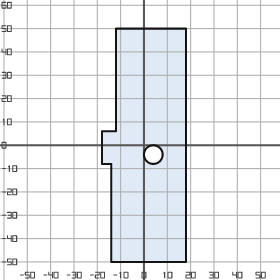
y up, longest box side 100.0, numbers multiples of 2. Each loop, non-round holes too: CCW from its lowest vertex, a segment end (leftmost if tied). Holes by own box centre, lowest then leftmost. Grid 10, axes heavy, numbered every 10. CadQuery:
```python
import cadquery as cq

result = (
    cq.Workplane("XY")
    .moveTo(-14.0, -50.0)
    .lineTo(18.0, -50.0)
    .lineTo(18.0, 50.0)
    .lineTo(-12.0, 50.0)
    .lineTo(-12.0, 6.0)
    .lineTo(-18.0, 6.0)
    .lineTo(-18.0, -8.0)
    .lineTo(-14.0, -8.0)
    .close()
    .moveTo(4.0, -4.0)
    .circle(4.0)
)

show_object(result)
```